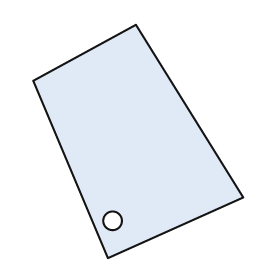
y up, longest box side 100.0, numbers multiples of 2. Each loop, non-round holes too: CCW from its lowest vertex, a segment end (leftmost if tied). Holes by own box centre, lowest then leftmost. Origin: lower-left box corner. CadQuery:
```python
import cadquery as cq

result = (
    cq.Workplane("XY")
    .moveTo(32.0, 0.0)
    .lineTo(90.0, 26.0)
    .lineTo(44.0, 100.0)
    .lineTo(0.0, 76.0)
    .close()
    .moveTo(34.0, 16.0)
    .circle(4.0)
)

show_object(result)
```